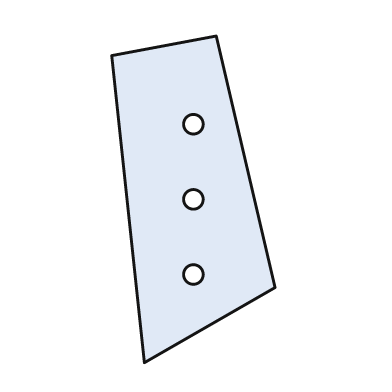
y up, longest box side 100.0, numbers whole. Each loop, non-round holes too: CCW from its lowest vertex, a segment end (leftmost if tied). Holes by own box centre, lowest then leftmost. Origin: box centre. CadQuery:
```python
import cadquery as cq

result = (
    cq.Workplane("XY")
    .moveTo(-15.0, -50.0)
    .lineTo(25.0, -27.0)
    .lineTo(7.0, 50.0)
    .lineTo(-25.0, 44.0)
    .close()
    .moveTo(0.0, -23.0)
    .circle(3.0)
    .moveTo(0.0, 0.0)
    .circle(3.0)
    .moveTo(0.0, 23.0)
    .circle(3.0)
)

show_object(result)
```